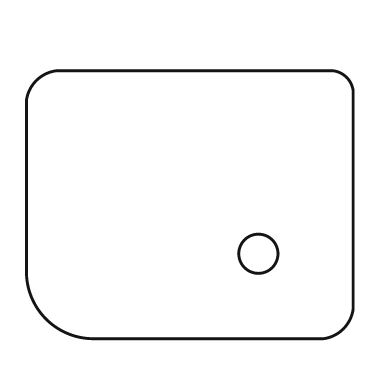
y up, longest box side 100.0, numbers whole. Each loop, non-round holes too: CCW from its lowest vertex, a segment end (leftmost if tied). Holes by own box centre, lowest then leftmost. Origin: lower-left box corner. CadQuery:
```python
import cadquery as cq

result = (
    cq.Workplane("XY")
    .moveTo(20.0, 0.0)
    .lineTo(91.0, 0.0)
    .threePointArc((97.0, 3.0), (100.0, 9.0))
    .lineTo(100.0, 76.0)
    .threePointArc((98.0, 80.0), (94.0, 82.0))
    .lineTo(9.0, 82.0)
    .threePointArc((3.0, 79.0), (0.0, 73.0))
    .lineTo(0.0, 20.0)
    .threePointArc((6.0, 6.0), (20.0, 0.0))
    .close()
    .moveTo(71.0, 26.0)
    .circle(6.0)
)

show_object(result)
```